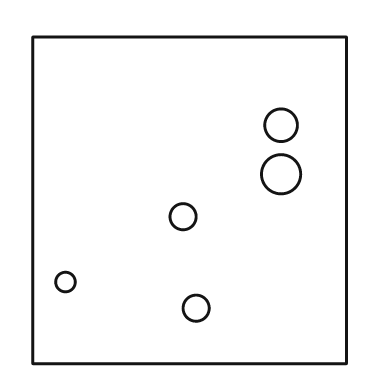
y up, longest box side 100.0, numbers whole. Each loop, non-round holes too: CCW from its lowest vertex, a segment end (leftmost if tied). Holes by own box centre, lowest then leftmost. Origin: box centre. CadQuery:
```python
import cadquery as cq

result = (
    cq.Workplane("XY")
    .moveTo(-48.0, -50.0)
    .lineTo(48.0, -50.0)
    .lineTo(48.0, 50.0)
    .lineTo(-48.0, 50.0)
    .close()
    .moveTo(2.0, -33.0)
    .circle(4.0)
    .moveTo(-38.0, -25.0)
    .circle(3.0)
    .moveTo(-2.0, -5.0)
    .circle(4.0)
    .moveTo(28.0, 8.0)
    .circle(6.0)
    .moveTo(28.0, 23.0)
    .circle(5.0)
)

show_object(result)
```